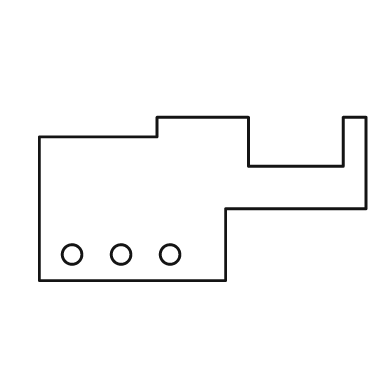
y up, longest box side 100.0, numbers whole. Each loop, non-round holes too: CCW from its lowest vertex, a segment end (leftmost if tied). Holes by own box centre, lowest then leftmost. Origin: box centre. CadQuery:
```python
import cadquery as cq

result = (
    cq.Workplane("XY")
    .moveTo(-50.0, -25.0)
    .lineTo(7.0, -25.0)
    .lineTo(7.0, -3.0)
    .lineTo(50.0, -3.0)
    .lineTo(50.0, 25.0)
    .lineTo(43.0, 25.0)
    .lineTo(43.0, 10.0)
    .lineTo(14.0, 10.0)
    .lineTo(14.0, 25.0)
    .lineTo(-14.0, 25.0)
    .lineTo(-14.0, 19.0)
    .lineTo(-50.0, 19.0)
    .close()
    .moveTo(-40.0, -17.0)
    .circle(3.0)
    .moveTo(-25.0, -17.0)
    .circle(3.0)
    .moveTo(-10.0, -17.0)
    .circle(3.0)
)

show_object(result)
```